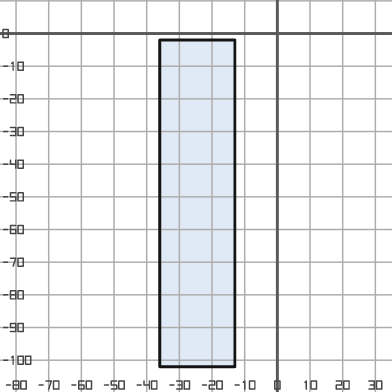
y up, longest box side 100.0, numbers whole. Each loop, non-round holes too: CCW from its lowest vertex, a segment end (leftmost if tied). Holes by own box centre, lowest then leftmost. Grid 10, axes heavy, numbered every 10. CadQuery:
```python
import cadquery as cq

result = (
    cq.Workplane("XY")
    .moveTo(-36.0, -102.0)
    .lineTo(-13.0, -102.0)
    .lineTo(-13.0, -2.0)
    .lineTo(-36.0, -2.0)
    .close()
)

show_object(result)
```